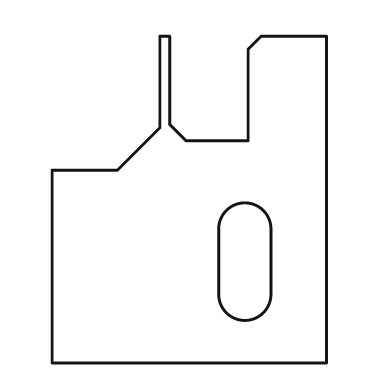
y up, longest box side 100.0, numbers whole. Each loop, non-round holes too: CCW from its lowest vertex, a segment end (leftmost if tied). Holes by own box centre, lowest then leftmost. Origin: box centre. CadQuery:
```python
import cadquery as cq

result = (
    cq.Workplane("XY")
    .moveTo(-42.0, -50.0)
    .lineTo(42.0, -50.0)
    .lineTo(42.0, 50.0)
    .lineTo(22.0, 50.0)
    .lineTo(18.0, 46.0)
    .lineTo(18.0, 18.0)
    .lineTo(-1.0, 18.0)
    .lineTo(-6.0, 23.0)
    .lineTo(-6.0, 50.0)
    .lineTo(-9.0, 50.0)
    .lineTo(-9.0, 22.0)
    .lineTo(-22.0, 9.0)
    .lineTo(-42.0, 9.0)
    .close()
    .moveTo(9.0, -29.0)
    .threePointArc((17.0, -37.0), (25.0, -29.0))
    .lineTo(25.0, -9.0)
    .threePointArc((17.0, -1.0), (9.0, -9.0))
    .close()
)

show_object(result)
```